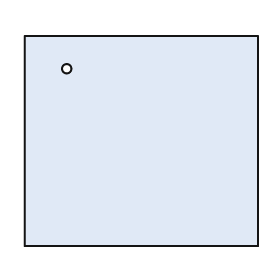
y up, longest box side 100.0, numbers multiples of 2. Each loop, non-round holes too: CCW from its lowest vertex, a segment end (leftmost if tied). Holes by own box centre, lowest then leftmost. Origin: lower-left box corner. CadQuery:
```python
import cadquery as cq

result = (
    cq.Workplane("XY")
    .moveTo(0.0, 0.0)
    .lineTo(100.0, 0.0)
    .lineTo(100.0, 90.0)
    .lineTo(0.0, 90.0)
    .close()
    .moveTo(18.0, 76.0)
    .circle(2.0)
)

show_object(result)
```